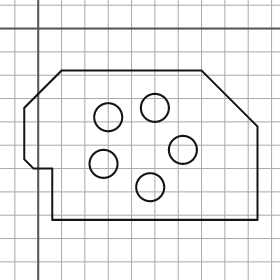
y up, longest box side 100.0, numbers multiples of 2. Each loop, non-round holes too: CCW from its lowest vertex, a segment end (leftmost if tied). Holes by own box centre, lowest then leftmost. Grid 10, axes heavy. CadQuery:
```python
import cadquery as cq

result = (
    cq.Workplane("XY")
    .moveTo(6.0, -82.0)
    .lineTo(94.0, -82.0)
    .lineTo(94.0, -42.0)
    .lineTo(70.0, -18.0)
    .lineTo(10.0, -18.0)
    .lineTo(-6.0, -34.0)
    .lineTo(-6.0, -56.0)
    .lineTo(-2.0, -60.0)
    .lineTo(6.0, -60.0)
    .close()
    .moveTo(48.0, -68.0)
    .circle(6.0)
    .moveTo(28.0, -58.0)
    .circle(6.0)
    .moveTo(62.0, -52.0)
    .circle(6.0)
    .moveTo(30.0, -38.0)
    .circle(6.0)
    .moveTo(50.0, -34.0)
    .circle(6.0)
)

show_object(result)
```